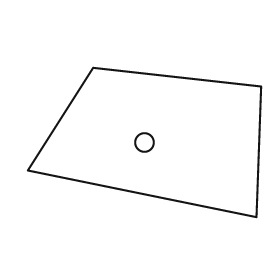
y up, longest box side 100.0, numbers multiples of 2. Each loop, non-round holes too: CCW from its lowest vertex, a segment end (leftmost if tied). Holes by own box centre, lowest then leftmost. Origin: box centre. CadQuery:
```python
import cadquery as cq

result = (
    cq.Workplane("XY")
    .moveTo(48.0, -32.0)
    .lineTo(50.0, 24.0)
    .lineTo(-22.0, 32.0)
    .lineTo(-50.0, -12.0)
    .close()
    .moveTo(0.0, 0.0)
    .circle(4.0)
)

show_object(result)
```